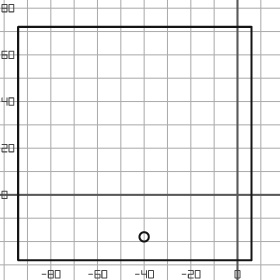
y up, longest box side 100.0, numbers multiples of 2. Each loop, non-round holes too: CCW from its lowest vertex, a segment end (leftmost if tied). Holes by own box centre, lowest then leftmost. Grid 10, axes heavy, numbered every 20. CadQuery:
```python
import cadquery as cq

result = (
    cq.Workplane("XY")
    .moveTo(-94.0, -28.0)
    .lineTo(6.0, -28.0)
    .lineTo(6.0, 72.0)
    .lineTo(-94.0, 72.0)
    .close()
    .moveTo(-40.0, -18.0)
    .circle(2.0)
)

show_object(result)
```